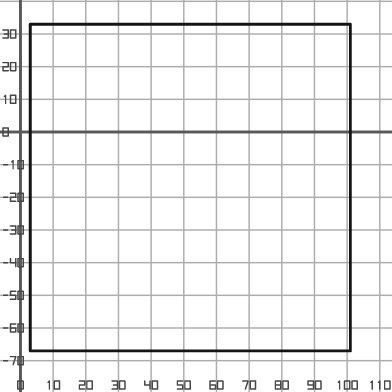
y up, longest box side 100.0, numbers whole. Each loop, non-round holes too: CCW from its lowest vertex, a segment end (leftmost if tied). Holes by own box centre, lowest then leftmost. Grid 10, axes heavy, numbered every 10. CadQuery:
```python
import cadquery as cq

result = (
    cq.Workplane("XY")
    .moveTo(3.0, -67.0)
    .lineTo(101.0, -67.0)
    .lineTo(101.0, 33.0)
    .lineTo(3.0, 33.0)
    .close()
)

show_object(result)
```